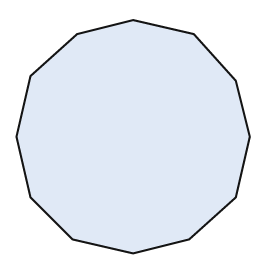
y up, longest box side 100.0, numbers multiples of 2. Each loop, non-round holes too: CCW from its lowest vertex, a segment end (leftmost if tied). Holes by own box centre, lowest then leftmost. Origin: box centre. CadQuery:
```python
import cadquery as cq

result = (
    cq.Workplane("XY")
    .moveTo(0.0, -50.0)
    .lineTo(24.0, -44.0)
    .lineTo(44.0, -26.0)
    .lineTo(50.0, 0.0)
    .lineTo(44.0, 24.0)
    .lineTo(26.0, 44.0)
    .lineTo(0.0, 50.0)
    .lineTo(-24.0, 44.0)
    .lineTo(-44.0, 26.0)
    .lineTo(-50.0, 0.0)
    .lineTo(-44.0, -26.0)
    .lineTo(-26.0, -44.0)
    .close()
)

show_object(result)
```